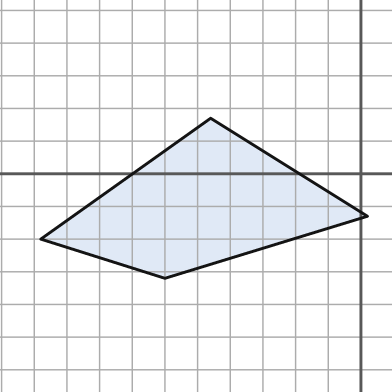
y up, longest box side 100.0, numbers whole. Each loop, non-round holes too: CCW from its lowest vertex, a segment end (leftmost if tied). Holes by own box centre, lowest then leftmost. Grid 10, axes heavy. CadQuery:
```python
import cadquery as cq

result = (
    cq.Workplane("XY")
    .moveTo(-60.0, -32.0)
    .lineTo(2.0, -13.0)
    .lineTo(-46.0, 17.0)
    .lineTo(-98.0, -20.0)
    .close()
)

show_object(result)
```